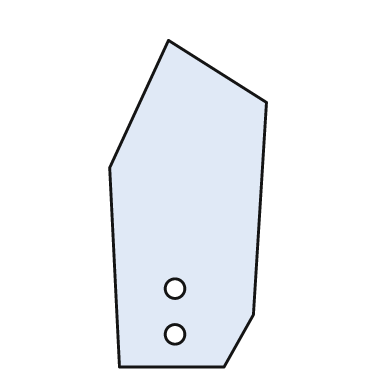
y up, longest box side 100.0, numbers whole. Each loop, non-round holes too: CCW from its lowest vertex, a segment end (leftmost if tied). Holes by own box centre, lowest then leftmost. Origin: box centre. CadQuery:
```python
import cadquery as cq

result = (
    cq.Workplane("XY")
    .moveTo(-21.0, -50.0)
    .lineTo(11.0, -50.0)
    .lineTo(20.0, -34.0)
    .lineTo(24.0, 31.0)
    .lineTo(-6.0, 50.0)
    .lineTo(-24.0, 11.0)
    .close()
    .moveTo(-4.0, -40.0)
    .circle(3.0)
    .moveTo(-4.0, -26.0)
    .circle(3.0)
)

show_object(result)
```